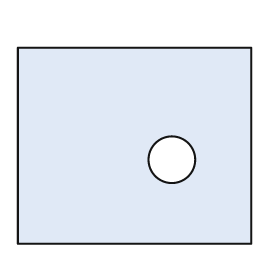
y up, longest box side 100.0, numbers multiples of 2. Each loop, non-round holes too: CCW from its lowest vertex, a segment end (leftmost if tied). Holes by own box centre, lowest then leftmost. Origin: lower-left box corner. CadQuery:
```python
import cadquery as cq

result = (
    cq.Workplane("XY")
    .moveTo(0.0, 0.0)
    .lineTo(100.0, 0.0)
    .lineTo(100.0, 84.0)
    .lineTo(0.0, 84.0)
    .close()
    .moveTo(66.0, 36.0)
    .circle(10.0)
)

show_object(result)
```